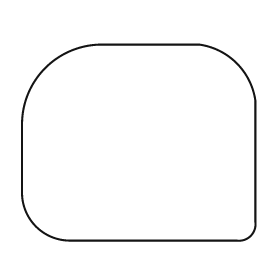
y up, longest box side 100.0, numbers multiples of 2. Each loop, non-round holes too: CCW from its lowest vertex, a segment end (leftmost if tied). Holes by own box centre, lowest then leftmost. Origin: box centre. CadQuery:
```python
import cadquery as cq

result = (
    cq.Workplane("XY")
    .moveTo(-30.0, -42.0)
    .lineTo(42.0, -42.0)
    .threePointArc((48.0, -40.0), (50.0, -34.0))
    .lineTo(50.0, 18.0)
    .threePointArc((42.0, 34.0), (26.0, 42.0))
    .lineTo(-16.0, 42.0)
    .threePointArc((-40.0, 32.0), (-50.0, 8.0))
    .lineTo(-50.0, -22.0)
    .threePointArc((-44.0, -36.0), (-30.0, -42.0))
    .close()
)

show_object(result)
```